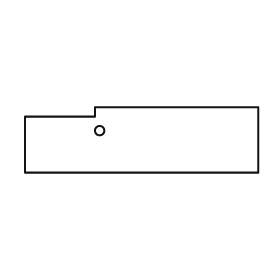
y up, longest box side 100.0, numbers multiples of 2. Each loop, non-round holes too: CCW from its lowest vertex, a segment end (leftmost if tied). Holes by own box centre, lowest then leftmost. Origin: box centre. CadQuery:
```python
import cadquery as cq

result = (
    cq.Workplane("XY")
    .moveTo(-50.0, -14.0)
    .lineTo(50.0, -14.0)
    .lineTo(50.0, 14.0)
    .lineTo(-20.0, 14.0)
    .lineTo(-20.0, 10.0)
    .lineTo(-50.0, 10.0)
    .close()
    .moveTo(-18.0, 4.0)
    .circle(2.0)
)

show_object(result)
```